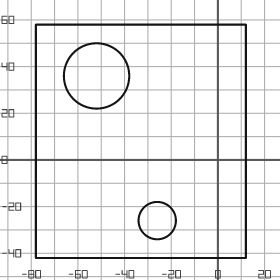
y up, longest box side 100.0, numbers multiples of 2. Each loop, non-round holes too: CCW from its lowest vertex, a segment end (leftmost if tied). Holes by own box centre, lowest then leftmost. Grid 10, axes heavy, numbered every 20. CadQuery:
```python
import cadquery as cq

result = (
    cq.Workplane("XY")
    .moveTo(-78.0, -42.0)
    .lineTo(12.0, -42.0)
    .lineTo(12.0, 58.0)
    .lineTo(-78.0, 58.0)
    .close()
    .moveTo(-26.0, -26.0)
    .circle(8.0)
    .moveTo(-52.0, 36.0)
    .circle(14.0)
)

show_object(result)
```